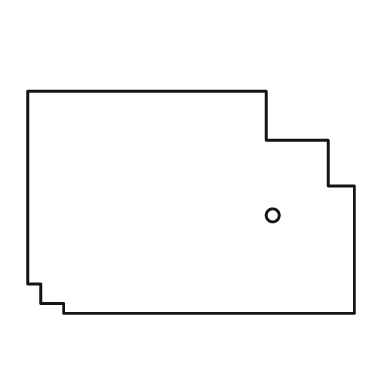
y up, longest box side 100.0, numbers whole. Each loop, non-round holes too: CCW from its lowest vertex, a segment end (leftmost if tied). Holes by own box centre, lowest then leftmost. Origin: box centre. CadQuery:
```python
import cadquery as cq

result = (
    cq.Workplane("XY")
    .moveTo(-39.0, -34.0)
    .lineTo(50.0, -34.0)
    .lineTo(50.0, 5.0)
    .lineTo(42.0, 5.0)
    .lineTo(42.0, 19.0)
    .lineTo(23.0, 19.0)
    .lineTo(23.0, 34.0)
    .lineTo(-50.0, 34.0)
    .lineTo(-50.0, -25.0)
    .lineTo(-46.0, -25.0)
    .lineTo(-46.0, -31.0)
    .lineTo(-39.0, -31.0)
    .close()
    .moveTo(25.0, -4.0)
    .circle(2.0)
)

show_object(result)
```